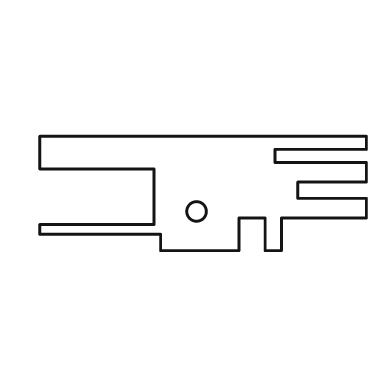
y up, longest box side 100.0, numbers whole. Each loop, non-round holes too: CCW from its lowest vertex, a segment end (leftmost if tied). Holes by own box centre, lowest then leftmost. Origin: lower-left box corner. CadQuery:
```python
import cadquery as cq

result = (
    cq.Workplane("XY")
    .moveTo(37.0, 0.0)
    .lineTo(61.0, 0.0)
    .lineTo(61.0, 10.0)
    .lineTo(69.0, 10.0)
    .lineTo(69.0, 0.0)
    .lineTo(74.0, 0.0)
    .lineTo(74.0, 10.0)
    .lineTo(100.0, 10.0)
    .lineTo(100.0, 16.0)
    .lineTo(79.0, 16.0)
    .lineTo(79.0, 21.0)
    .lineTo(100.0, 21.0)
    .lineTo(100.0, 27.0)
    .lineTo(72.0, 27.0)
    .lineTo(72.0, 31.0)
    .lineTo(100.0, 31.0)
    .lineTo(100.0, 35.0)
    .lineTo(0.0, 35.0)
    .lineTo(0.0, 25.0)
    .lineTo(35.0, 25.0)
    .lineTo(35.0, 8.0)
    .lineTo(0.0, 8.0)
    .lineTo(0.0, 5.0)
    .lineTo(37.0, 5.0)
    .close()
    .moveTo(48.0, 12.0)
    .circle(3.0)
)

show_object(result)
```